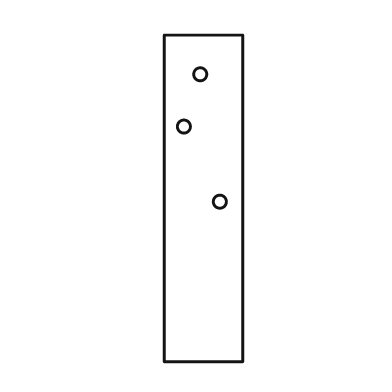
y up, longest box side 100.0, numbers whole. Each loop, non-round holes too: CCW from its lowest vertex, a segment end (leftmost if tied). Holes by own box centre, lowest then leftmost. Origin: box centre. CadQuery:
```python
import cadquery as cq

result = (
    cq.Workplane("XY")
    .moveTo(-12.0, -50.0)
    .lineTo(12.0, -50.0)
    .lineTo(12.0, 50.0)
    .lineTo(-12.0, 50.0)
    .close()
    .moveTo(5.0, -1.0)
    .circle(2.0)
    .moveTo(-6.0, 22.0)
    .circle(2.0)
    .moveTo(-1.0, 38.0)
    .circle(2.0)
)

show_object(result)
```